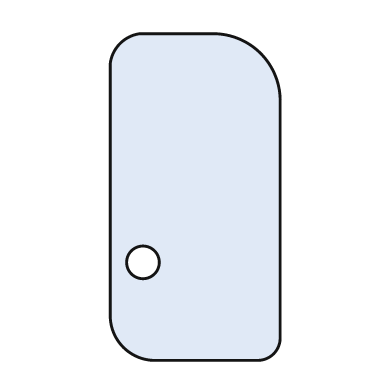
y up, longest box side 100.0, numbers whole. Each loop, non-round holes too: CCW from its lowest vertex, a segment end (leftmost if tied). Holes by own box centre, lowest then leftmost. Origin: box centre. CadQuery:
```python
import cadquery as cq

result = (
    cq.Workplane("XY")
    .moveTo(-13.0, -50.0)
    .lineTo(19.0, -50.0)
    .threePointArc((24.0, -48.0), (26.0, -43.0))
    .lineTo(26.0, 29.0)
    .threePointArc((20.0, 44.0), (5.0, 50.0))
    .lineTo(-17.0, 50.0)
    .threePointArc((-23.0, 47.0), (-26.0, 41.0))
    .lineTo(-26.0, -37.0)
    .threePointArc((-22.0, -46.0), (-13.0, -50.0))
    .close()
    .moveTo(-16.0, -20.0)
    .circle(5.0)
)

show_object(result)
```